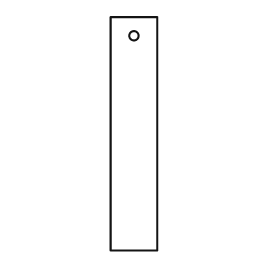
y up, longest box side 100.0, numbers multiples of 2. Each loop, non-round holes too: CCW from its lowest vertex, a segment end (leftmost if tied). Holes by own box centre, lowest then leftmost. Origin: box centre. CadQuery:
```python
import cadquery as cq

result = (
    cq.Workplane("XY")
    .moveTo(-10.0, -50.0)
    .lineTo(10.0, -50.0)
    .lineTo(10.0, 50.0)
    .lineTo(-10.0, 50.0)
    .close()
    .moveTo(0.0, 42.0)
    .circle(2.0)
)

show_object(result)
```